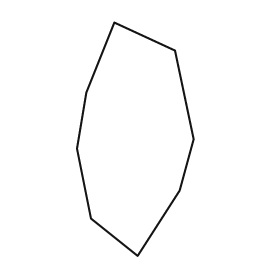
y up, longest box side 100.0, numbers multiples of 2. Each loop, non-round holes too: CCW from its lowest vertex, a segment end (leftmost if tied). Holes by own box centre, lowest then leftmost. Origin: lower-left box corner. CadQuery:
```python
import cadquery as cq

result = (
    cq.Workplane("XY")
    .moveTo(26.0, 0.0)
    .lineTo(44.0, 28.0)
    .lineTo(50.0, 50.0)
    .lineTo(42.0, 88.0)
    .lineTo(16.0, 100.0)
    .lineTo(4.0, 70.0)
    .lineTo(0.0, 46.0)
    .lineTo(6.0, 16.0)
    .close()
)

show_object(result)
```